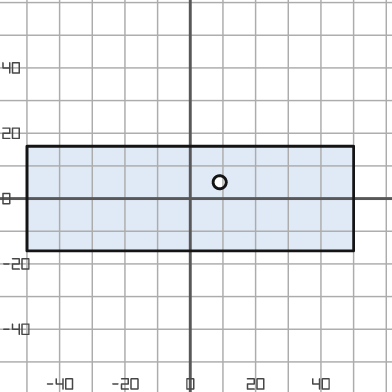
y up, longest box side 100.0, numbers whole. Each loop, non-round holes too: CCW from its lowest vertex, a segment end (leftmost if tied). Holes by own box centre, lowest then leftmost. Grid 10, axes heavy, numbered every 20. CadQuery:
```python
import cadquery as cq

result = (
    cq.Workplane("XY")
    .moveTo(-50.0, -16.0)
    .lineTo(50.0, -16.0)
    .lineTo(50.0, 16.0)
    .lineTo(-50.0, 16.0)
    .close()
    .moveTo(9.0, 5.0)
    .circle(2.0)
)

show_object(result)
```